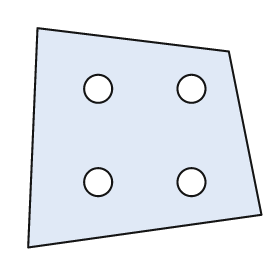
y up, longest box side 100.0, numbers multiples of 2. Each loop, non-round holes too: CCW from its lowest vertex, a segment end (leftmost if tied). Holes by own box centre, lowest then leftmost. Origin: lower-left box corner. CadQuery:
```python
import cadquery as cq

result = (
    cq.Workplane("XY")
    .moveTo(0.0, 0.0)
    .lineTo(100.0, 14.0)
    .lineTo(86.0, 84.0)
    .lineTo(4.0, 94.0)
    .close()
    .moveTo(30.0, 28.0)
    .circle(6.0)
    .moveTo(70.0, 28.0)
    .circle(6.0)
    .moveTo(30.0, 68.0)
    .circle(6.0)
    .moveTo(70.0, 68.0)
    .circle(6.0)
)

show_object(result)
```